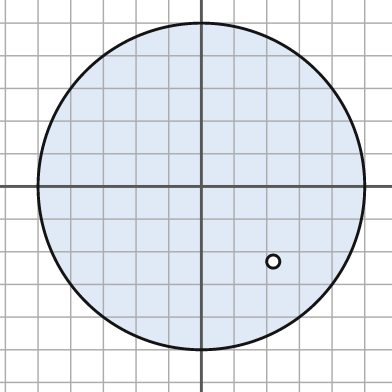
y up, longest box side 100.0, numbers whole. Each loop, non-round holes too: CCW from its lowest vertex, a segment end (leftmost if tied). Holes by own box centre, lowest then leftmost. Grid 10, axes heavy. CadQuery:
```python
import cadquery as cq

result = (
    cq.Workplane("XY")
    .moveTo(0.0, 0.0)
    .circle(50.0)
    .moveTo(22.0, -23.0)
    .circle(2.0)
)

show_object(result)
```